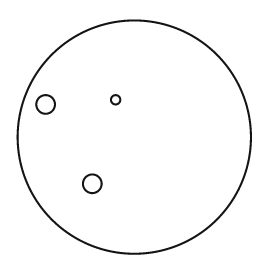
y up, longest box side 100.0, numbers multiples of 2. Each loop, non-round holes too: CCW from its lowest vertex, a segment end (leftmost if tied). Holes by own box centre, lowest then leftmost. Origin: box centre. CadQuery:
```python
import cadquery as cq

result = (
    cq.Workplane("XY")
    .moveTo(0.0, 0.0)
    .circle(50.0)
    .moveTo(-18.0, -20.0)
    .circle(4.0)
    .moveTo(-38.0, 14.0)
    .circle(4.0)
    .moveTo(-8.0, 16.0)
    .circle(2.0)
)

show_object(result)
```